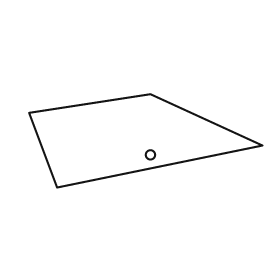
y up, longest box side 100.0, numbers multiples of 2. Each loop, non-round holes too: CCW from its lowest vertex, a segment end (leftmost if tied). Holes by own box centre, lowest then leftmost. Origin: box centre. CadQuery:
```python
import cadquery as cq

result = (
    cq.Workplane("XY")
    .moveTo(-38.0, -20.0)
    .lineTo(50.0, -2.0)
    .lineTo(2.0, 20.0)
    .lineTo(-50.0, 12.0)
    .close()
    .moveTo(2.0, -6.0)
    .circle(2.0)
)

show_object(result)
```